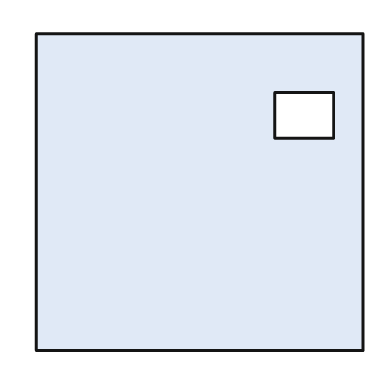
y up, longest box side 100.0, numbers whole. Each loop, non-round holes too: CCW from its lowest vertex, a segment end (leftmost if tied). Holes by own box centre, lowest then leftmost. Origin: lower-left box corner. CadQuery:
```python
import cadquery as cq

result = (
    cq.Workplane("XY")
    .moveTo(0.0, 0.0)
    .lineTo(100.0, 0.0)
    .lineTo(100.0, 97.0)
    .lineTo(0.0, 97.0)
    .close()
    .moveTo(73.0, 65.0)
    .lineTo(91.0, 65.0)
    .lineTo(91.0, 79.0)
    .lineTo(73.0, 79.0)
    .close()
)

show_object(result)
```